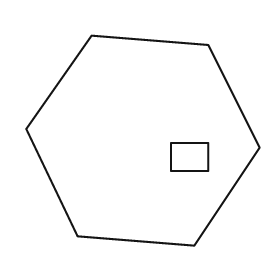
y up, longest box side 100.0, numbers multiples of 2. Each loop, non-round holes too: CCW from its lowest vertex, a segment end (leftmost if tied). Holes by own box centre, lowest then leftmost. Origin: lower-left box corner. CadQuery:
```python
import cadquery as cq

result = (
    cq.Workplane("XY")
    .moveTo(72.0, 0.0)
    .lineTo(100.0, 42.0)
    .lineTo(78.0, 86.0)
    .lineTo(28.0, 90.0)
    .lineTo(0.0, 50.0)
    .lineTo(22.0, 4.0)
    .close()
    .moveTo(62.0, 32.0)
    .lineTo(78.0, 32.0)
    .lineTo(78.0, 44.0)
    .lineTo(62.0, 44.0)
    .close()
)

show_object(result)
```